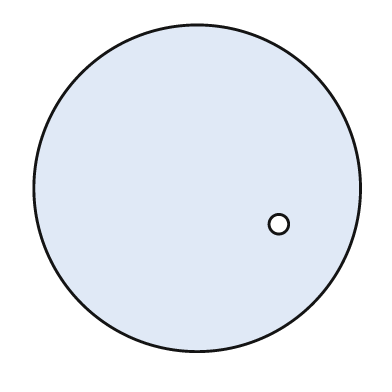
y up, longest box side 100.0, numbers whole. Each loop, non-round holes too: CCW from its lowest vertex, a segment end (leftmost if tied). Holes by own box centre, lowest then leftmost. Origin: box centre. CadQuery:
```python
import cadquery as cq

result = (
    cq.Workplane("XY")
    .moveTo(0.0, 0.0)
    .circle(50.0)
    .moveTo(25.0, -11.0)
    .circle(3.0)
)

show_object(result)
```